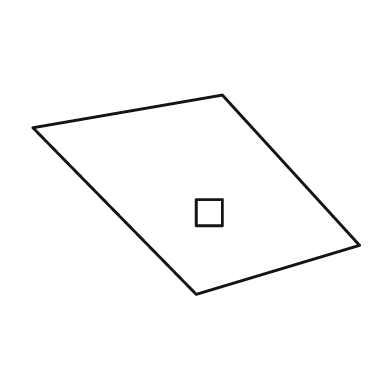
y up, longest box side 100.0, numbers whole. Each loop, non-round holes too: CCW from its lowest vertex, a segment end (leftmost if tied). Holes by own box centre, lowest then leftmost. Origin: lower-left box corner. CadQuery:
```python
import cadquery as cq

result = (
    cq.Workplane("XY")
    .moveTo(50.0, 0.0)
    .lineTo(100.0, 15.0)
    .lineTo(58.0, 61.0)
    .lineTo(0.0, 51.0)
    .close()
    .moveTo(50.0, 21.0)
    .lineTo(58.0, 21.0)
    .lineTo(58.0, 29.0)
    .lineTo(50.0, 29.0)
    .close()
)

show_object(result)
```